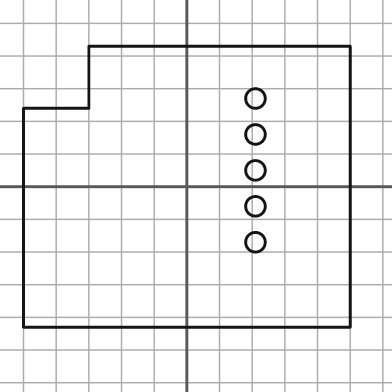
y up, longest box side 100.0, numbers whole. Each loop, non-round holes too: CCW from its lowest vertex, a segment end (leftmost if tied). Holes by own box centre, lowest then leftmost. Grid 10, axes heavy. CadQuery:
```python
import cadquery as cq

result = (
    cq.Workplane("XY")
    .moveTo(-50.0, -43.0)
    .lineTo(50.0, -43.0)
    .lineTo(50.0, 43.0)
    .lineTo(-30.0, 43.0)
    .lineTo(-30.0, 24.0)
    .lineTo(-50.0, 24.0)
    .close()
    .moveTo(21.0, -17.0)
    .circle(3.0)
    .moveTo(21.0, -6.0)
    .circle(3.0)
    .moveTo(21.0, 5.0)
    .circle(3.0)
    .moveTo(21.0, 16.0)
    .circle(3.0)
    .moveTo(21.0, 27.0)
    .circle(3.0)
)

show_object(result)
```